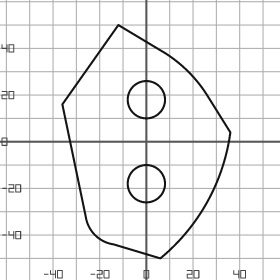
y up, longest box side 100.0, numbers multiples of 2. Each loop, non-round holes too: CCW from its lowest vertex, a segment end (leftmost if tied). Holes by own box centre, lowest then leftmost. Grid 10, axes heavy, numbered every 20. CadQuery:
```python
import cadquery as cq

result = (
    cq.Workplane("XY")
    .moveTo(6.0, -50.0)
    .threePointArc((26.0, -26.0), (36.0, 4.0))
    .lineTo(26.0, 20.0)
    .threePointArc((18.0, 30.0), (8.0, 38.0))
    .lineTo(-12.0, 50.0)
    .lineTo(-36.0, 16.0)
    .lineTo(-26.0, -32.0)
    .threePointArc((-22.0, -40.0), (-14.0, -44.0))
    .close()
    .moveTo(0.0, -18.0)
    .circle(8.0)
    .moveTo(0.0, 18.0)
    .circle(8.0)
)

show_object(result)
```